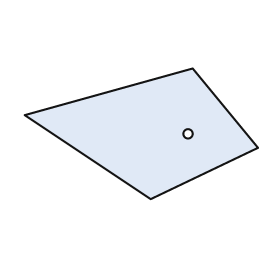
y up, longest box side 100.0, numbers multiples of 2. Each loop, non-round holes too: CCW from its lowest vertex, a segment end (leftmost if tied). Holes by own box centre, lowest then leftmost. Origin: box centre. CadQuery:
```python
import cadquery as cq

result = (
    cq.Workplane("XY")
    .moveTo(4.0, -28.0)
    .lineTo(50.0, -6.0)
    .lineTo(22.0, 28.0)
    .lineTo(-50.0, 8.0)
    .close()
    .moveTo(20.0, 0.0)
    .circle(2.0)
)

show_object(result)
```